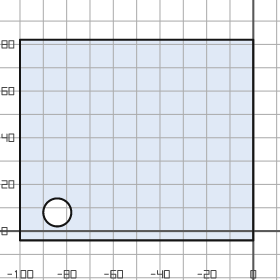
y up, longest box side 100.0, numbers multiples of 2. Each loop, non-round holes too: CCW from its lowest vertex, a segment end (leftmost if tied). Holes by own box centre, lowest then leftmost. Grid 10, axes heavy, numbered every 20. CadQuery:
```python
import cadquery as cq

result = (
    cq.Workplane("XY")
    .moveTo(-100.0, -4.0)
    .lineTo(0.0, -4.0)
    .lineTo(0.0, 82.0)
    .lineTo(-100.0, 82.0)
    .close()
    .moveTo(-84.0, 8.0)
    .circle(6.0)
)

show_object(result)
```